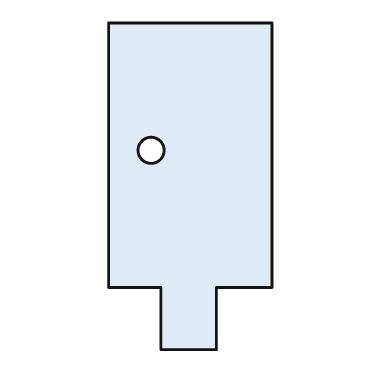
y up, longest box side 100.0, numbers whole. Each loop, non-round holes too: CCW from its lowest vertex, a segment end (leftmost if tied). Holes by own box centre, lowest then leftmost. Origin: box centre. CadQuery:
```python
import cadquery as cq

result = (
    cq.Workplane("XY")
    .moveTo(-9.0, -50.0)
    .lineTo(8.0, -50.0)
    .lineTo(8.0, -31.0)
    .lineTo(25.0, -31.0)
    .lineTo(25.0, 50.0)
    .lineTo(-25.0, 50.0)
    .lineTo(-25.0, -31.0)
    .lineTo(-9.0, -31.0)
    .close()
    .moveTo(-12.0, 11.0)
    .circle(4.0)
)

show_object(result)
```